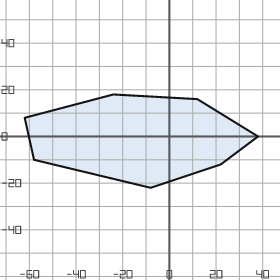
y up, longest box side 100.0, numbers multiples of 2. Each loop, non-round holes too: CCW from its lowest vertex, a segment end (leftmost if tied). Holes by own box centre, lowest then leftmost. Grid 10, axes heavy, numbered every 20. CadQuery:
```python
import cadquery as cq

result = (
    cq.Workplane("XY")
    .moveTo(-8.0, -22.0)
    .lineTo(22.0, -12.0)
    .lineTo(38.0, 0.0)
    .lineTo(12.0, 16.0)
    .lineTo(-24.0, 18.0)
    .lineTo(-62.0, 8.0)
    .lineTo(-58.0, -10.0)
    .close()
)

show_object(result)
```